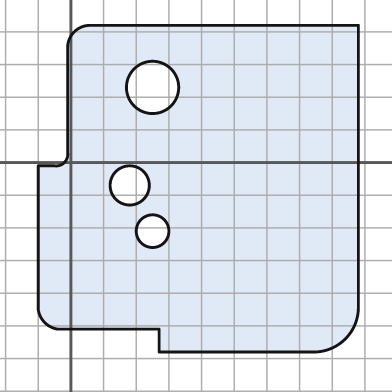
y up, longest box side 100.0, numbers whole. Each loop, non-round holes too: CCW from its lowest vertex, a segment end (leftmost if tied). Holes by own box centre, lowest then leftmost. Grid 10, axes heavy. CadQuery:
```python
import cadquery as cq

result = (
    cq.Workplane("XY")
    .moveTo(27.0, -58.0)
    .lineTo(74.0, -58.0)
    .threePointArc((84.0, -54.0), (88.0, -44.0))
    .lineTo(88.0, 42.0)
    .lineTo(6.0, 42.0)
    .threePointArc((1.0, 40.0), (-1.0, 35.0))
    .lineTo(-1.0, 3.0)
    .threePointArc((-2.0, 0.0), (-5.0, -1.0))
    .lineTo(-10.0, -1.0)
    .lineTo(-10.0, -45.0)
    .threePointArc((-8.0, -49.0), (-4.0, -51.0))
    .lineTo(27.0, -51.0)
    .close()
    .moveTo(25.0, -21.0)
    .circle(5.0)
    .moveTo(18.0, -7.0)
    .circle(6.0)
    .moveTo(25.0, 23.0)
    .circle(8.0)
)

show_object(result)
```